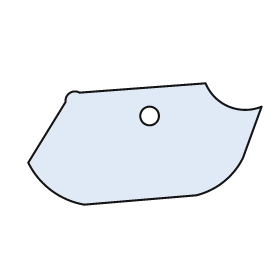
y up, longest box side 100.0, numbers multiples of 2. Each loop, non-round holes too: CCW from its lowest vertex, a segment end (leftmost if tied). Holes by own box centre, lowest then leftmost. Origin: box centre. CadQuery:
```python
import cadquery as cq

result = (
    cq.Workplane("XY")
    .moveTo(-26.0, -26.0)
    .lineTo(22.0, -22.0)
    .threePointArc((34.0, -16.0), (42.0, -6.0))
    .lineTo(50.0, 16.0)
    .threePointArc((36.0, 16.0), (26.0, 26.0))
    .lineTo(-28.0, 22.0)
    .threePointArc((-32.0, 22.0), (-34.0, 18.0))
    .lineTo(-50.0, -8.0)
    .threePointArc((-40.0, -20.0), (-26.0, -26.0))
    .close()
    .moveTo(2.0, 12.0)
    .circle(4.0)
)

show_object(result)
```